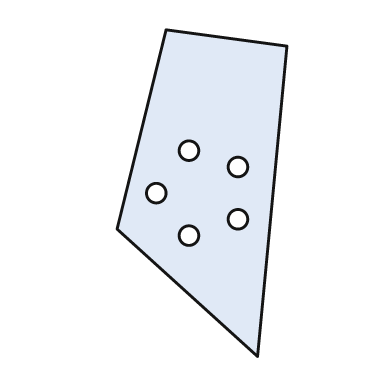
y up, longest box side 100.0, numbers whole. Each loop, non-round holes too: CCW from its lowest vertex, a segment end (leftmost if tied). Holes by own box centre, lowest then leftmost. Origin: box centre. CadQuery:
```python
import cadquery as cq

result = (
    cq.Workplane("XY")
    .moveTo(17.0, -50.0)
    .lineTo(26.0, 45.0)
    .lineTo(-11.0, 50.0)
    .lineTo(-26.0, -11.0)
    .close()
    .moveTo(-4.0, -13.0)
    .circle(3.0)
    .moveTo(11.0, -8.0)
    .circle(3.0)
    .moveTo(-14.0, 0.0)
    .circle(3.0)
    .moveTo(11.0, 8.0)
    .circle(3.0)
    .moveTo(-4.0, 13.0)
    .circle(3.0)
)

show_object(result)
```